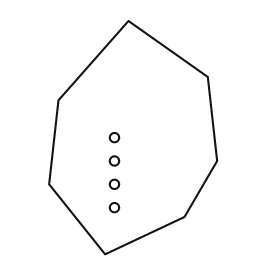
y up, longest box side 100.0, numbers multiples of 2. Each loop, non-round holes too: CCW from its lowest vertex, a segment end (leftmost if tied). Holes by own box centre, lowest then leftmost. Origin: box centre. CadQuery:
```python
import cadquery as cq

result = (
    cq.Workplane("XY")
    .moveTo(-12.0, -50.0)
    .lineTo(22.0, -34.0)
    .lineTo(36.0, -10.0)
    .lineTo(32.0, 26.0)
    .lineTo(-2.0, 50.0)
    .lineTo(-32.0, 16.0)
    .lineTo(-36.0, -20.0)
    .close()
    .moveTo(-8.0, -30.0)
    .circle(2.0)
    .moveTo(-8.0, -20.0)
    .circle(2.0)
    .moveTo(-8.0, -10.0)
    .circle(2.0)
    .moveTo(-8.0, 0.0)
    .circle(2.0)
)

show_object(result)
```